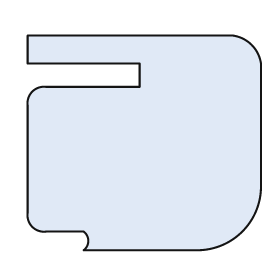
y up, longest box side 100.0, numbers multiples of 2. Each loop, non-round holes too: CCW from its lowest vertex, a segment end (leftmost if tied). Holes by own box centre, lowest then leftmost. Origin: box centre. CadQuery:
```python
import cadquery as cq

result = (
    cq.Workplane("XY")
    .moveTo(-26.0, -46.0)
    .lineTo(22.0, -46.0)
    .threePointArc((42.0, -38.0), (50.0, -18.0))
    .lineTo(50.0, 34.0)
    .threePointArc((46.0, 42.0), (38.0, 46.0))
    .lineTo(-50.0, 46.0)
    .lineTo(-50.0, 34.0)
    .lineTo(-2.0, 34.0)
    .lineTo(-2.0, 24.0)
    .lineTo(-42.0, 24.0)
    .threePointArc((-48.0, 22.0), (-50.0, 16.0))
    .lineTo(-50.0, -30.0)
    .threePointArc((-48.0, -36.0), (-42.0, -38.0))
    .lineTo(-26.0, -38.0)
    .threePointArc((-24.0, -42.0), (-26.0, -46.0))
    .close()
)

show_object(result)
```